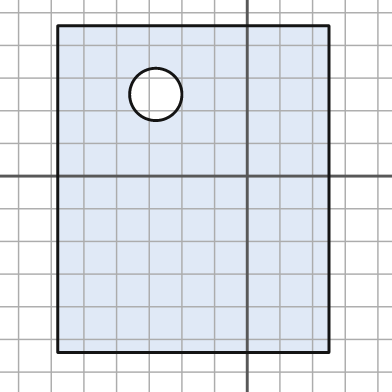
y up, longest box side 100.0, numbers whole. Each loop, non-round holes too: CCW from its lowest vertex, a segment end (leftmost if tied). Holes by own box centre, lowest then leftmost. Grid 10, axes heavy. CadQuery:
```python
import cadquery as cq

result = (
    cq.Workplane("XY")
    .moveTo(-58.0, -54.0)
    .lineTo(25.0, -54.0)
    .lineTo(25.0, 46.0)
    .lineTo(-58.0, 46.0)
    .close()
    .moveTo(-28.0, 25.0)
    .circle(8.0)
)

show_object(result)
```